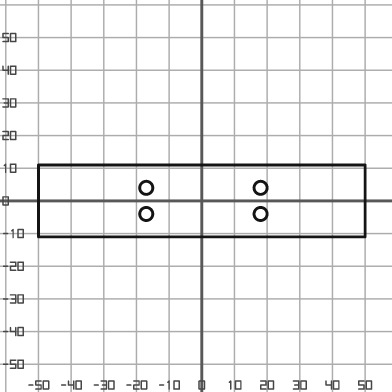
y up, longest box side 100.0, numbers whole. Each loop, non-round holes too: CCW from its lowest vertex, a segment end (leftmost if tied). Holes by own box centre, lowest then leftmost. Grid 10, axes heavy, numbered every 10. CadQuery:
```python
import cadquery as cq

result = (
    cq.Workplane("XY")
    .moveTo(-50.0, -11.0)
    .lineTo(50.0, -11.0)
    .lineTo(50.0, 11.0)
    .lineTo(-50.0, 11.0)
    .close()
    .moveTo(-17.0, -4.0)
    .circle(2.0)
    .moveTo(18.0, -4.0)
    .circle(2.0)
    .moveTo(-17.0, 4.0)
    .circle(2.0)
    .moveTo(18.0, 4.0)
    .circle(2.0)
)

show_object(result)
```